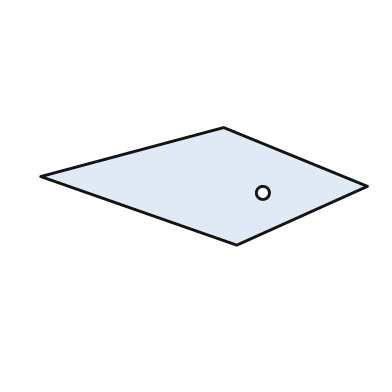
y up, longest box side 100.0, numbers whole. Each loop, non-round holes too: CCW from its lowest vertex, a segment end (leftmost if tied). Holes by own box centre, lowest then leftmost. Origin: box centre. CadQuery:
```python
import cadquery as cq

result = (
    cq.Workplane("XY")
    .moveTo(10.0, -18.0)
    .lineTo(50.0, 0.0)
    .lineTo(6.0, 18.0)
    .lineTo(-50.0, 3.0)
    .close()
    .moveTo(18.0, -2.0)
    .circle(2.0)
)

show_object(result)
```